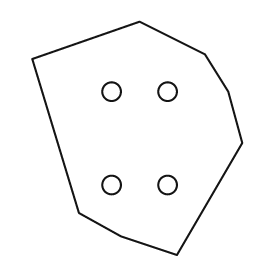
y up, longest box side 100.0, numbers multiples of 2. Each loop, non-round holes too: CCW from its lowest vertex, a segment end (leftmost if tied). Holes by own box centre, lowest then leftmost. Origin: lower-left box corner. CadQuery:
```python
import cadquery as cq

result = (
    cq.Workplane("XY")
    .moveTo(62.0, 0.0)
    .lineTo(90.0, 48.0)
    .lineTo(84.0, 70.0)
    .lineTo(74.0, 86.0)
    .lineTo(46.0, 100.0)
    .lineTo(0.0, 84.0)
    .lineTo(20.0, 18.0)
    .lineTo(38.0, 8.0)
    .close()
    .moveTo(34.0, 30.0)
    .circle(4.0)
    .moveTo(58.0, 30.0)
    .circle(4.0)
    .moveTo(34.0, 70.0)
    .circle(4.0)
    .moveTo(58.0, 70.0)
    .circle(4.0)
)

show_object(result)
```